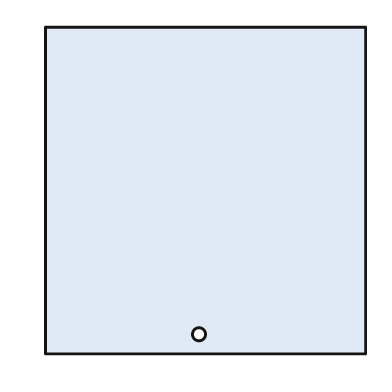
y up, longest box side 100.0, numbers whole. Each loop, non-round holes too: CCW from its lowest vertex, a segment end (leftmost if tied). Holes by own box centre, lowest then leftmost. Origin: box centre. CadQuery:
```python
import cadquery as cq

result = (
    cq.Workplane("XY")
    .moveTo(-49.0, -50.0)
    .lineTo(49.0, -50.0)
    .lineTo(49.0, 50.0)
    .lineTo(-49.0, 50.0)
    .close()
    .moveTo(-2.0, -44.0)
    .circle(2.0)
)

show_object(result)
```